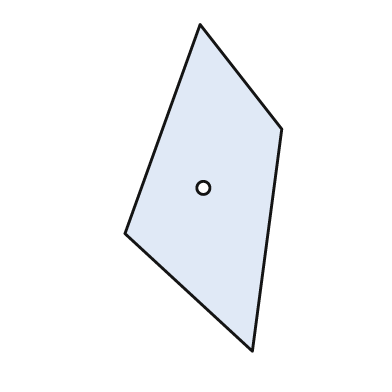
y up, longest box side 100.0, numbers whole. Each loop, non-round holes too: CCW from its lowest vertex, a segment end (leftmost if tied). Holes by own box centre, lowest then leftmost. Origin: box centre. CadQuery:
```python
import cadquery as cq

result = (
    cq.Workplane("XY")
    .moveTo(15.0, -50.0)
    .lineTo(24.0, 18.0)
    .lineTo(-1.0, 50.0)
    .lineTo(-24.0, -14.0)
    .close()
    .moveTo(0.0, 0.0)
    .circle(2.0)
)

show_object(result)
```